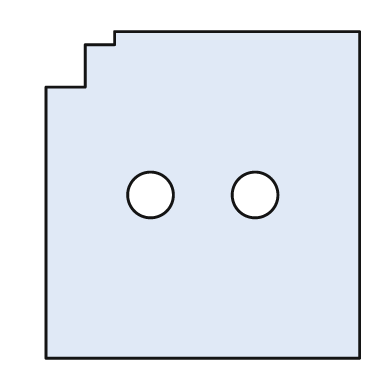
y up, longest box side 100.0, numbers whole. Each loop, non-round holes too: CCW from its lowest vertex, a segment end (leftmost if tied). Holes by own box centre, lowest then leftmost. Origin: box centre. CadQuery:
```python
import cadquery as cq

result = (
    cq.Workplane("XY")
    .moveTo(-48.0, -50.0)
    .lineTo(48.0, -50.0)
    .lineTo(48.0, 50.0)
    .lineTo(-27.0, 50.0)
    .lineTo(-27.0, 46.0)
    .lineTo(-36.0, 46.0)
    .lineTo(-36.0, 33.0)
    .lineTo(-48.0, 33.0)
    .close()
    .moveTo(-16.0, 0.0)
    .circle(7.0)
    .moveTo(16.0, 0.0)
    .circle(7.0)
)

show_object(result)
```